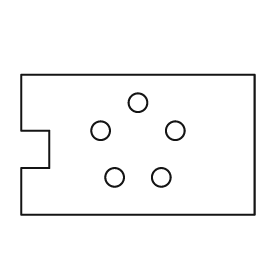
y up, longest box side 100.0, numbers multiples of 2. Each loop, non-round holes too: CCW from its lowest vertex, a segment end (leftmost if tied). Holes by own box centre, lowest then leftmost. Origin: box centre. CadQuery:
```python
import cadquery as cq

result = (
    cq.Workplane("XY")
    .moveTo(-50.0, -30.0)
    .lineTo(50.0, -30.0)
    .lineTo(50.0, 30.0)
    .lineTo(-50.0, 30.0)
    .lineTo(-50.0, 6.0)
    .lineTo(-38.0, 6.0)
    .lineTo(-38.0, -10.0)
    .lineTo(-50.0, -10.0)
    .close()
    .moveTo(-10.0, -14.0)
    .circle(4.0)
    .moveTo(10.0, -14.0)
    .circle(4.0)
    .moveTo(-16.0, 6.0)
    .circle(4.0)
    .moveTo(16.0, 6.0)
    .circle(4.0)
    .moveTo(0.0, 18.0)
    .circle(4.0)
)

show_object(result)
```